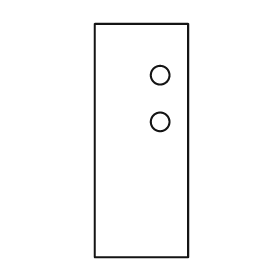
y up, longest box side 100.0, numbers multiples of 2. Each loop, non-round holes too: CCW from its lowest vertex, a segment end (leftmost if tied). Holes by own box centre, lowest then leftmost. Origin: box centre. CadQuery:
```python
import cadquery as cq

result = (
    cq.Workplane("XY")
    .moveTo(-20.0, -50.0)
    .lineTo(20.0, -50.0)
    .lineTo(20.0, 50.0)
    .lineTo(-20.0, 50.0)
    .close()
    .moveTo(8.0, 8.0)
    .circle(4.0)
    .moveTo(8.0, 28.0)
    .circle(4.0)
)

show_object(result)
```